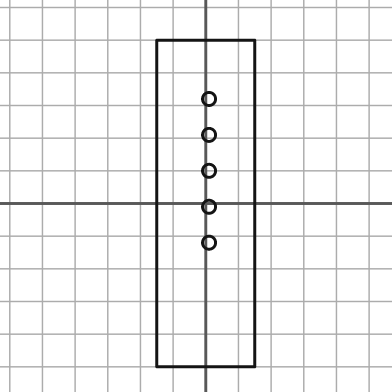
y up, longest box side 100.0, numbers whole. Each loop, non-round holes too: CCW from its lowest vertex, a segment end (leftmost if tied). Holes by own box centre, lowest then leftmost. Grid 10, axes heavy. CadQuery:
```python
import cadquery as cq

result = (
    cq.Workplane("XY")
    .moveTo(-15.0, -50.0)
    .lineTo(15.0, -50.0)
    .lineTo(15.0, 50.0)
    .lineTo(-15.0, 50.0)
    .close()
    .moveTo(1.0, -12.0)
    .circle(2.0)
    .moveTo(1.0, -1.0)
    .circle(2.0)
    .moveTo(1.0, 10.0)
    .circle(2.0)
    .moveTo(1.0, 21.0)
    .circle(2.0)
    .moveTo(1.0, 32.0)
    .circle(2.0)
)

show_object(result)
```